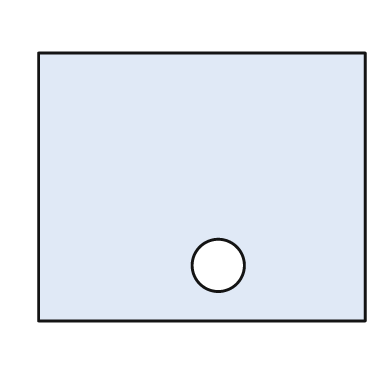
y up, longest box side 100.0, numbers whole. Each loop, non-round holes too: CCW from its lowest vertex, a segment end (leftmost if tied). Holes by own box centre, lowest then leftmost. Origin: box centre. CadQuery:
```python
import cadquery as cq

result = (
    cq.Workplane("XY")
    .moveTo(-50.0, -41.0)
    .lineTo(50.0, -41.0)
    .lineTo(50.0, 41.0)
    .lineTo(-50.0, 41.0)
    .close()
    .moveTo(5.0, -24.0)
    .circle(8.0)
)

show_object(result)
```